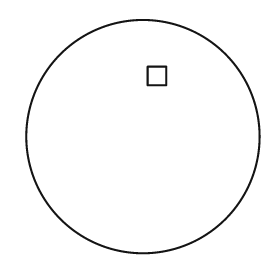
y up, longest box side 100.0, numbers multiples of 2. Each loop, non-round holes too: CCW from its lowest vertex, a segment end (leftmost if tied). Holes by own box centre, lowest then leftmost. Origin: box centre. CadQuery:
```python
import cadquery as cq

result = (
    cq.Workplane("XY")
    .moveTo(0.0, 0.0)
    .circle(50.0)
    .moveTo(2.0, 22.0)
    .lineTo(10.0, 22.0)
    .lineTo(10.0, 30.0)
    .lineTo(2.0, 30.0)
    .close()
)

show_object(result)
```